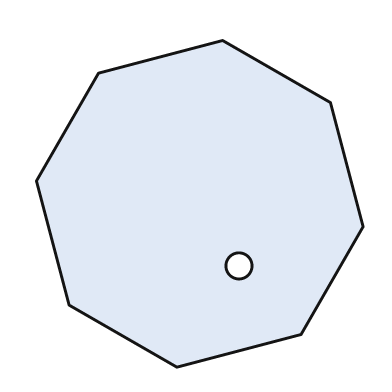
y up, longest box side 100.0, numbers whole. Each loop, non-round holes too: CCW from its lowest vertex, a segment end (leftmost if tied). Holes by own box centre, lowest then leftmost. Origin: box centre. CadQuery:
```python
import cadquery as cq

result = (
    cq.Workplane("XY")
    .moveTo(-7.0, -50.0)
    .lineTo(31.0, -40.0)
    .lineTo(50.0, -7.0)
    .lineTo(40.0, 31.0)
    .lineTo(7.0, 50.0)
    .lineTo(-31.0, 40.0)
    .lineTo(-50.0, 7.0)
    .lineTo(-40.0, -31.0)
    .close()
    .moveTo(12.0, -19.0)
    .circle(4.0)
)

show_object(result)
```